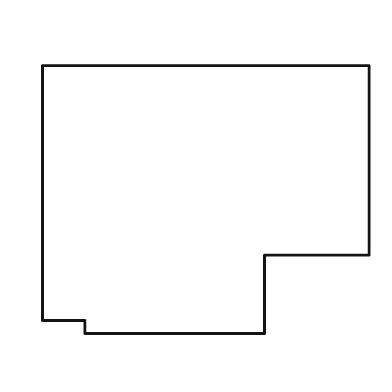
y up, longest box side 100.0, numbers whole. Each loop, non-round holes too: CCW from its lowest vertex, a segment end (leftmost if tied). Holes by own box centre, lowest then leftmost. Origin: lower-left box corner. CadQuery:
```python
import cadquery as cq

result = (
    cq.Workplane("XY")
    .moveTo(13.0, 0.0)
    .lineTo(68.0, 0.0)
    .lineTo(68.0, 24.0)
    .lineTo(100.0, 24.0)
    .lineTo(100.0, 82.0)
    .lineTo(0.0, 82.0)
    .lineTo(0.0, 4.0)
    .lineTo(13.0, 4.0)
    .close()
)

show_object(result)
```